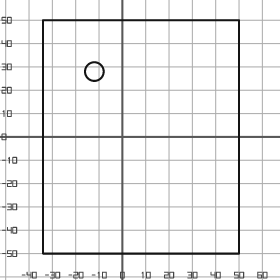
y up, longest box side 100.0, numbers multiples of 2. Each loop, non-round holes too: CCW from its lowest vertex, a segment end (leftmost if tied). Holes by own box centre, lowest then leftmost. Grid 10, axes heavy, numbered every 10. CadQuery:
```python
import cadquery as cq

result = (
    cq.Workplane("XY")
    .moveTo(-34.0, -50.0)
    .lineTo(50.0, -50.0)
    .lineTo(50.0, 50.0)
    .lineTo(-34.0, 50.0)
    .close()
    .moveTo(-12.0, 28.0)
    .circle(4.0)
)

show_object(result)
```